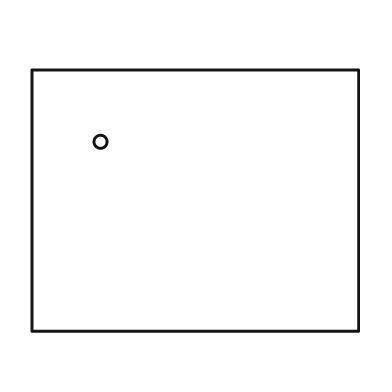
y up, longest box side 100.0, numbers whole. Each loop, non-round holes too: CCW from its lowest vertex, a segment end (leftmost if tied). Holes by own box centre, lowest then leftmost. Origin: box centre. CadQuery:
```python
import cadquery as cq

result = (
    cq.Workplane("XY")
    .moveTo(-50.0, -40.0)
    .lineTo(50.0, -40.0)
    .lineTo(50.0, 40.0)
    .lineTo(-50.0, 40.0)
    .close()
    .moveTo(-29.0, 18.0)
    .circle(2.0)
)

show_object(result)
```